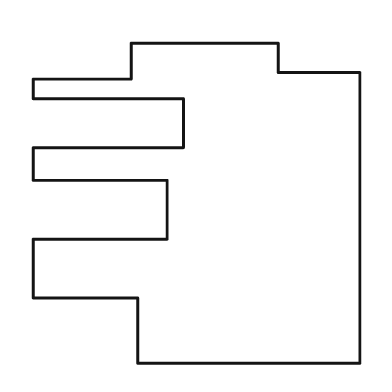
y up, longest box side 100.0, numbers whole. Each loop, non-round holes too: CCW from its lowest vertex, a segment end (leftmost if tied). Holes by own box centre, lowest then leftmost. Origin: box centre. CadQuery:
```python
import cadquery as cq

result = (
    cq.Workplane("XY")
    .moveTo(-18.0, -49.0)
    .lineTo(50.0, -49.0)
    .lineTo(50.0, 40.0)
    .lineTo(25.0, 40.0)
    .lineTo(25.0, 49.0)
    .lineTo(-20.0, 49.0)
    .lineTo(-20.0, 38.0)
    .lineTo(-50.0, 38.0)
    .lineTo(-50.0, 32.0)
    .lineTo(-4.0, 32.0)
    .lineTo(-4.0, 17.0)
    .lineTo(-50.0, 17.0)
    .lineTo(-50.0, 7.0)
    .lineTo(-9.0, 7.0)
    .lineTo(-9.0, -11.0)
    .lineTo(-50.0, -11.0)
    .lineTo(-50.0, -29.0)
    .lineTo(-18.0, -29.0)
    .close()
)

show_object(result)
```